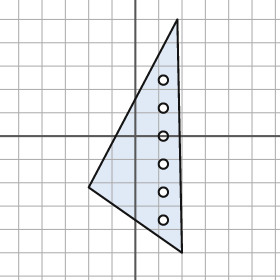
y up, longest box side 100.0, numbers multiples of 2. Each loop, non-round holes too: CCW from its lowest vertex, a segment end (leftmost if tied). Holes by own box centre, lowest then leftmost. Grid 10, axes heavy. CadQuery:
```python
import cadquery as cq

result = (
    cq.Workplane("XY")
    .moveTo(20.0, -50.0)
    .lineTo(18.0, 50.0)
    .lineTo(-20.0, -22.0)
    .close()
    .moveTo(12.0, -36.0)
    .circle(2.0)
    .moveTo(12.0, -24.0)
    .circle(2.0)
    .moveTo(12.0, -12.0)
    .circle(2.0)
    .moveTo(12.0, 0.0)
    .circle(2.0)
    .moveTo(12.0, 12.0)
    .circle(2.0)
    .moveTo(12.0, 24.0)
    .circle(2.0)
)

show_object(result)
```